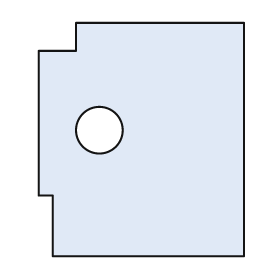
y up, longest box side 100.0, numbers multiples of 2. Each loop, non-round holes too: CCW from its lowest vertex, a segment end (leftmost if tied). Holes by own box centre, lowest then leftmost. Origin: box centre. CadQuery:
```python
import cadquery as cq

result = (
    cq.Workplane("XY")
    .moveTo(-38.0, -50.0)
    .lineTo(44.0, -50.0)
    .lineTo(44.0, 50.0)
    .lineTo(-28.0, 50.0)
    .lineTo(-28.0, 38.0)
    .lineTo(-44.0, 38.0)
    .lineTo(-44.0, -24.0)
    .lineTo(-38.0, -24.0)
    .close()
    .moveTo(-18.0, 4.0)
    .circle(10.0)
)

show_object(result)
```